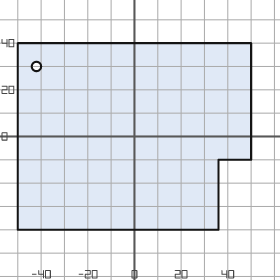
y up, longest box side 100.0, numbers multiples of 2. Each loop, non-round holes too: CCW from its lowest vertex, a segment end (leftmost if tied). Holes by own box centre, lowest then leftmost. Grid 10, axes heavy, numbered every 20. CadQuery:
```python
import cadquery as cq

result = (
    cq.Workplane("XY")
    .moveTo(-50.0, -40.0)
    .lineTo(36.0, -40.0)
    .lineTo(36.0, -10.0)
    .lineTo(50.0, -10.0)
    .lineTo(50.0, 40.0)
    .lineTo(-50.0, 40.0)
    .close()
    .moveTo(-42.0, 30.0)
    .circle(2.0)
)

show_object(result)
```